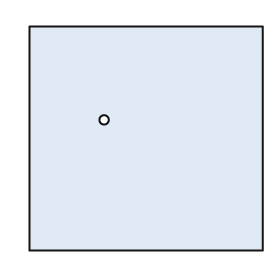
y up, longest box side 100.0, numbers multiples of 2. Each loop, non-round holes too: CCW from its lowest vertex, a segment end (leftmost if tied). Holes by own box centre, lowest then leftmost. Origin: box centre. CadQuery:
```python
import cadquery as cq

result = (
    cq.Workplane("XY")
    .moveTo(-50.0, -48.0)
    .lineTo(50.0, -48.0)
    .lineTo(50.0, 48.0)
    .lineTo(-50.0, 48.0)
    .close()
    .moveTo(-18.0, 8.0)
    .circle(2.0)
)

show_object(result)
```